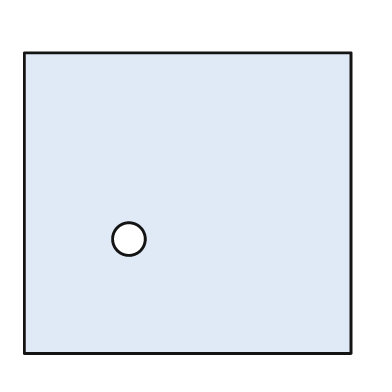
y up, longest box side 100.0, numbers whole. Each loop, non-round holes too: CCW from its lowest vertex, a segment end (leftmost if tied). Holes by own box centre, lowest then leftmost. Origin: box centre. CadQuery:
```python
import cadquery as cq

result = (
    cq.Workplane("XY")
    .moveTo(-50.0, -46.0)
    .lineTo(50.0, -46.0)
    .lineTo(50.0, 46.0)
    .lineTo(-50.0, 46.0)
    .close()
    .moveTo(-18.0, -11.0)
    .circle(5.0)
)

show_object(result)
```